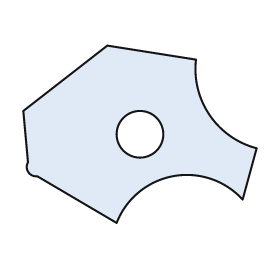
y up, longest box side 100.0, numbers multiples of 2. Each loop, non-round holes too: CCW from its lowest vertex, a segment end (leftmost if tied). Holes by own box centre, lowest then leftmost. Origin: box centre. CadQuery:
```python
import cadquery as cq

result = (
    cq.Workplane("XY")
    .moveTo(-10.0, -38.0)
    .threePointArc((14.0, -18.0), (44.0, -28.0))
    .lineTo(50.0, -6.0)
    .threePointArc((30.0, 8.0), (24.0, 32.0))
    .lineTo(-14.0, 38.0)
    .lineTo(-50.0, 10.0)
    .lineTo(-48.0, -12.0)
    .threePointArc((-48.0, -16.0), (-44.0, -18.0))
    .close()
    .moveTo(0.0, 0.0)
    .circle(10.0)
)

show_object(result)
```